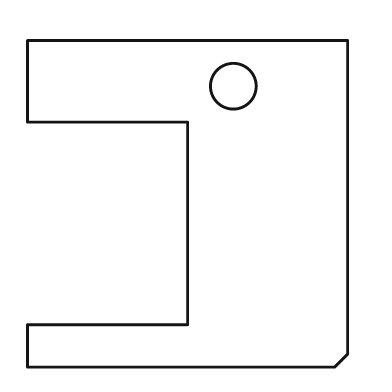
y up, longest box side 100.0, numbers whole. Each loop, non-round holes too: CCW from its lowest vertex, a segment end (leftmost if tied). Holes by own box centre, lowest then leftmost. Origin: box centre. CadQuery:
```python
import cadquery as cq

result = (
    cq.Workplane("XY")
    .moveTo(-49.0, -50.0)
    .lineTo(45.0, -50.0)
    .lineTo(49.0, -46.0)
    .lineTo(49.0, 50.0)
    .lineTo(-49.0, 50.0)
    .lineTo(-49.0, 25.0)
    .lineTo(0.0, 25.0)
    .lineTo(0.0, -37.0)
    .lineTo(-49.0, -37.0)
    .close()
    .moveTo(14.0, 36.0)
    .circle(7.0)
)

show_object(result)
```